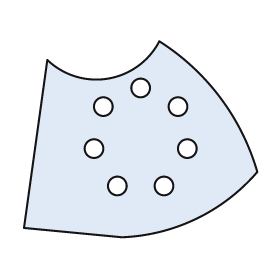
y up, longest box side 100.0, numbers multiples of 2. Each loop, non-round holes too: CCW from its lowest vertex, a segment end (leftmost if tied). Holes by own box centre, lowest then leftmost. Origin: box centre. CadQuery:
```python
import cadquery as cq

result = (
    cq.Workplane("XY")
    .moveTo(-8.0, -42.0)
    .threePointArc((24.0, -34.0), (50.0, -14.0))
    .threePointArc((34.0, 18.0), (8.0, 42.0))
    .threePointArc((-14.0, 26.0), (-40.0, 34.0))
    .lineTo(-50.0, -38.0)
    .close()
    .moveTo(-10.0, -20.0)
    .circle(4.0)
    .moveTo(10.0, -20.0)
    .circle(4.0)
    .moveTo(-20.0, -4.0)
    .circle(4.0)
    .moveTo(20.0, -4.0)
    .circle(4.0)
    .moveTo(-16.0, 14.0)
    .circle(4.0)
    .moveTo(16.0, 14.0)
    .circle(4.0)
    .moveTo(0.0, 22.0)
    .circle(4.0)
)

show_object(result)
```